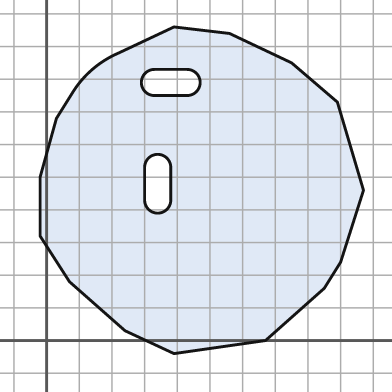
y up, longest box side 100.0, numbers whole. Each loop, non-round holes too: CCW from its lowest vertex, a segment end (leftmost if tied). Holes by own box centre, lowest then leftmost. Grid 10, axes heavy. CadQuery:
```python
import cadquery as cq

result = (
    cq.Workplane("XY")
    .moveTo(39.0, -4.0)
    .lineTo(67.0, 0.0)
    .lineTo(85.0, 16.0)
    .lineTo(90.0, 24.0)
    .lineTo(97.0, 46.0)
    .lineTo(89.0, 73.0)
    .lineTo(75.0, 85.0)
    .lineTo(56.0, 94.0)
    .lineTo(39.0, 96.0)
    .lineTo(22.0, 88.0)
    .threePointArc((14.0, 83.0), (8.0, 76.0))
    .lineTo(3.0, 68.0)
    .lineTo(-2.0, 50.0)
    .lineTo(-2.0, 32.0)
    .lineTo(7.0, 18.0)
    .lineTo(24.0, 3.0)
    .close()
    .moveTo(30.0, 43.0)
    .threePointArc((34.0, 39.0), (38.0, 43.0))
    .lineTo(38.0, 53.0)
    .threePointArc((34.0, 57.0), (30.0, 53.0))
    .close()
    .moveTo(33.0, 75.0)
    .lineTo(43.0, 75.0)
    .threePointArc((47.0, 79.0), (43.0, 83.0))
    .lineTo(33.0, 83.0)
    .threePointArc((29.0, 79.0), (33.0, 75.0))
    .close()
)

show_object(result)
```